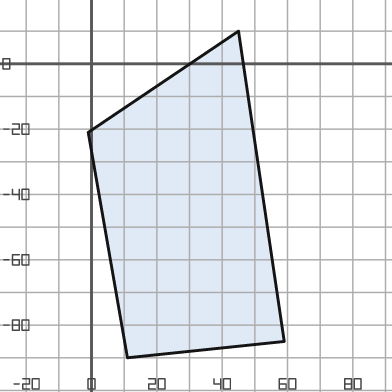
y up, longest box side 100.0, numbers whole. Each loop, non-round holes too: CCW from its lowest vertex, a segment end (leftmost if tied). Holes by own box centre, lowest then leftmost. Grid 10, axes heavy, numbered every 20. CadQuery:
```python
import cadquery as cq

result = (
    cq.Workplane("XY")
    .moveTo(11.0, -90.0)
    .lineTo(59.0, -85.0)
    .lineTo(45.0, 10.0)
    .lineTo(-1.0, -21.0)
    .close()
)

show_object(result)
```